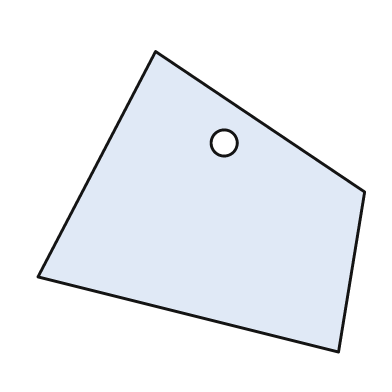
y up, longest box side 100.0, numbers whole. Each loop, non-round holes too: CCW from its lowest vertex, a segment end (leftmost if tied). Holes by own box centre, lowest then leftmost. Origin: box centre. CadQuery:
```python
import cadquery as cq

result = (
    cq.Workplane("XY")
    .moveTo(42.0, -46.0)
    .lineTo(50.0, 3.0)
    .lineTo(-14.0, 46.0)
    .lineTo(-50.0, -23.0)
    .close()
    .moveTo(7.0, 18.0)
    .circle(4.0)
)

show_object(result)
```